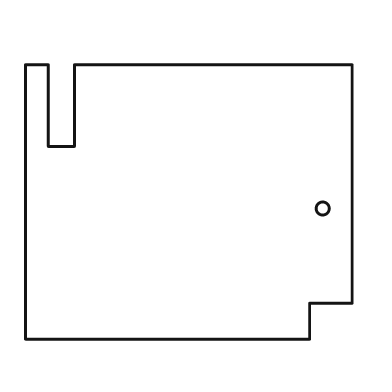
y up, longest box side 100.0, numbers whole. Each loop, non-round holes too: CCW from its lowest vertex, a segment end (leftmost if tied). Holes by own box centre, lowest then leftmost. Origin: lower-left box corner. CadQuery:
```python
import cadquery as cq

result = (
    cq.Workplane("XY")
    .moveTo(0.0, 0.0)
    .lineTo(87.0, 0.0)
    .lineTo(87.0, 11.0)
    .lineTo(100.0, 11.0)
    .lineTo(100.0, 84.0)
    .lineTo(15.0, 84.0)
    .lineTo(15.0, 59.0)
    .lineTo(7.0, 59.0)
    .lineTo(7.0, 84.0)
    .lineTo(0.0, 84.0)
    .close()
    .moveTo(91.0, 40.0)
    .circle(2.0)
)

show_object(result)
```